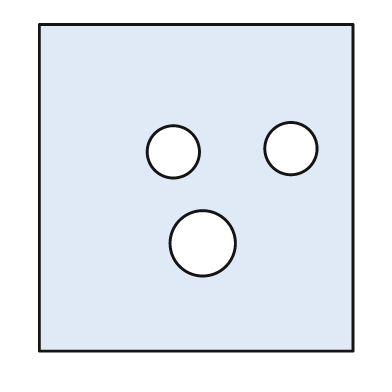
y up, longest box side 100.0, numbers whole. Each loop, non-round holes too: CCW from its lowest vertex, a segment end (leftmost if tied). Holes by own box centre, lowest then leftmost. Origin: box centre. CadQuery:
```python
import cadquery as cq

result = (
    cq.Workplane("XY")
    .moveTo(-48.0, -50.0)
    .lineTo(48.0, -50.0)
    .lineTo(48.0, 50.0)
    .lineTo(-48.0, 50.0)
    .close()
    .moveTo(2.0, -17.0)
    .circle(10.0)
    .moveTo(-7.0, 11.0)
    .circle(8.0)
    .moveTo(29.0, 12.0)
    .circle(8.0)
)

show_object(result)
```